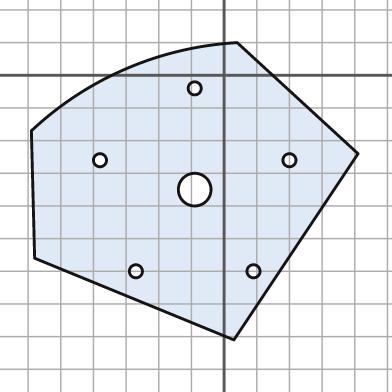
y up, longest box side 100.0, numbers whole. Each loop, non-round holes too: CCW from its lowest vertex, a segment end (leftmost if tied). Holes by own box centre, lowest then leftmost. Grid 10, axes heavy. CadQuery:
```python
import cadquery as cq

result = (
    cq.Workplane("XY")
    .moveTo(3.0, -81.0)
    .lineTo(41.0, -24.0)
    .lineTo(4.0, 10.0)
    .threePointArc((-30.0, 2.0), (-59.0, -17.0))
    .lineTo(-58.0, -56.0)
    .close()
    .moveTo(-27.0, -60.0)
    .circle(2.0)
    .moveTo(9.0, -60.0)
    .circle(2.0)
    .moveTo(-9.0, -35.0)
    .circle(5.0)
    .moveTo(-38.0, -26.0)
    .circle(2.0)
    .moveTo(20.0, -26.0)
    .circle(2.0)
    .moveTo(-9.0, -4.0)
    .circle(2.0)
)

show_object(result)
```